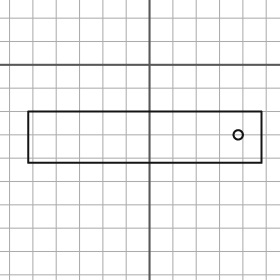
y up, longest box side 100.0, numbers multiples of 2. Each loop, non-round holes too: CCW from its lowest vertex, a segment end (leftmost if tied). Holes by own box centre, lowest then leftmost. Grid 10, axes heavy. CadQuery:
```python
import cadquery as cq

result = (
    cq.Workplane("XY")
    .moveTo(-52.0, -42.0)
    .lineTo(48.0, -42.0)
    .lineTo(48.0, -20.0)
    .lineTo(-52.0, -20.0)
    .close()
    .moveTo(38.0, -30.0)
    .circle(2.0)
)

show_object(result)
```